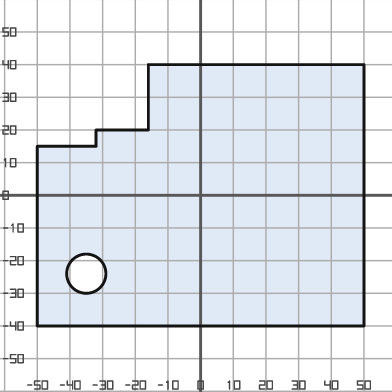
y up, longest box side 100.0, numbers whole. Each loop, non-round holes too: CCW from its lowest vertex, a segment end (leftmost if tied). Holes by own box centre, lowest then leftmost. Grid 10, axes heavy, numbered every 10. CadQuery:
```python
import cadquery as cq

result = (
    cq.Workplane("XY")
    .moveTo(-50.0, -40.0)
    .lineTo(50.0, -40.0)
    .lineTo(50.0, 40.0)
    .lineTo(-16.0, 40.0)
    .lineTo(-16.0, 20.0)
    .lineTo(-32.0, 20.0)
    .lineTo(-32.0, 15.0)
    .lineTo(-50.0, 15.0)
    .close()
    .moveTo(-35.0, -24.0)
    .circle(6.0)
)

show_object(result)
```